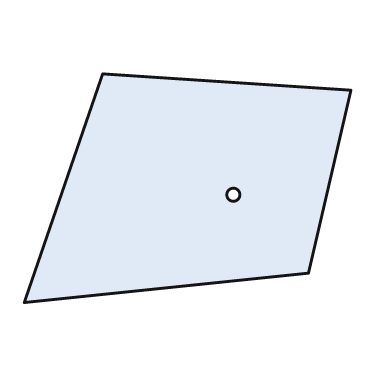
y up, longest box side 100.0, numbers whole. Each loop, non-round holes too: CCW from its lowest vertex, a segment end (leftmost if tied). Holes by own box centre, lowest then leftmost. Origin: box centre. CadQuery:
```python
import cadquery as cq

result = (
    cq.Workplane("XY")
    .moveTo(-50.0, -35.0)
    .lineTo(37.0, -26.0)
    .lineTo(50.0, 30.0)
    .lineTo(-26.0, 35.0)
    .close()
    .moveTo(14.0, -2.0)
    .circle(2.0)
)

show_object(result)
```